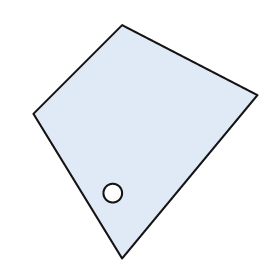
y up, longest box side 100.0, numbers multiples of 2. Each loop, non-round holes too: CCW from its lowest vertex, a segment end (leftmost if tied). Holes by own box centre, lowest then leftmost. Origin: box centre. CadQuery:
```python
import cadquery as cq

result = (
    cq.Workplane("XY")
    .moveTo(-10.0, -50.0)
    .lineTo(48.0, 20.0)
    .lineTo(-10.0, 50.0)
    .lineTo(-48.0, 12.0)
    .close()
    .moveTo(-14.0, -22.0)
    .circle(4.0)
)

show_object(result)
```